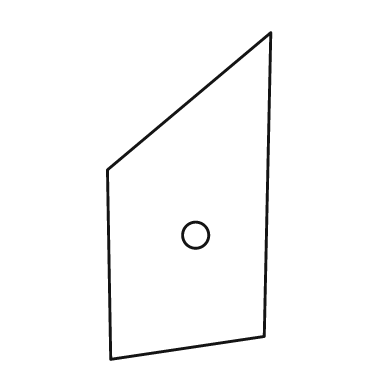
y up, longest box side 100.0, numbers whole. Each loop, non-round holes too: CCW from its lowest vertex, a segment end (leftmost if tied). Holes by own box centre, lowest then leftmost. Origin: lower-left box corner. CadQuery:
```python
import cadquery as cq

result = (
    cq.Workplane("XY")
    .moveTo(1.0, 0.0)
    .lineTo(48.0, 7.0)
    .lineTo(50.0, 100.0)
    .lineTo(0.0, 58.0)
    .close()
    .moveTo(27.0, 38.0)
    .circle(4.0)
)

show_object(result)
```